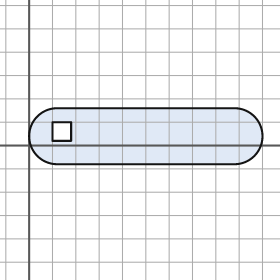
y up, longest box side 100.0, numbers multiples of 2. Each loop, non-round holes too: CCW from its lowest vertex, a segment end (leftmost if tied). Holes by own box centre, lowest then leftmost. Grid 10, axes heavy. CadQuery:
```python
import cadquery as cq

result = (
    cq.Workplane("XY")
    .moveTo(12.0, -8.0)
    .lineTo(88.0, -8.0)
    .threePointArc((100.0, 4.0), (88.0, 16.0))
    .lineTo(12.0, 16.0)
    .threePointArc((0.0, 4.0), (12.0, -8.0))
    .close()
    .moveTo(10.0, 2.0)
    .lineTo(18.0, 2.0)
    .lineTo(18.0, 10.0)
    .lineTo(10.0, 10.0)
    .close()
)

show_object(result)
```